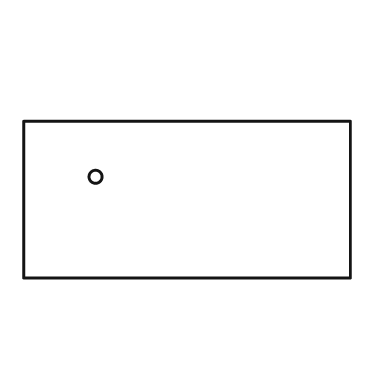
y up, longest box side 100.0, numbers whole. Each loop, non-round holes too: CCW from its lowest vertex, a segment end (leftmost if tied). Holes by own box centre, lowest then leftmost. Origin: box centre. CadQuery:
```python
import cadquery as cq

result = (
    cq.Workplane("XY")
    .moveTo(-50.0, -24.0)
    .lineTo(50.0, -24.0)
    .lineTo(50.0, 24.0)
    .lineTo(-50.0, 24.0)
    .close()
    .moveTo(-28.0, 7.0)
    .circle(2.0)
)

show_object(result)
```